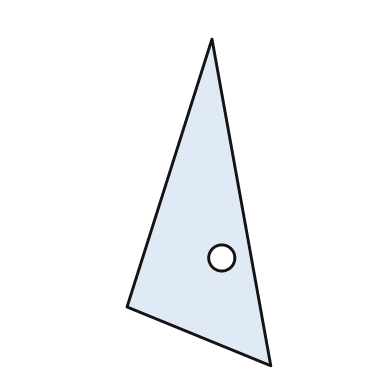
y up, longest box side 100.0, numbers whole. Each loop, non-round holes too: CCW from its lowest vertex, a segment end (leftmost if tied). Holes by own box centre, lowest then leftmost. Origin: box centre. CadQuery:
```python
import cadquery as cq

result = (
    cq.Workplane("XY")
    .moveTo(22.0, -50.0)
    .lineTo(4.0, 50.0)
    .lineTo(-22.0, -32.0)
    .close()
    .moveTo(7.0, -17.0)
    .circle(4.0)
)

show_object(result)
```